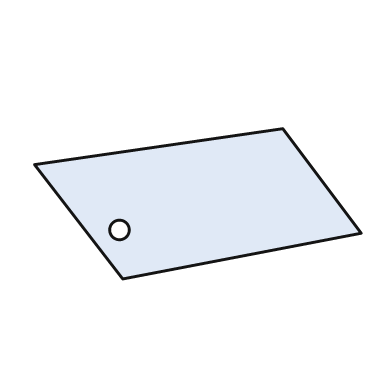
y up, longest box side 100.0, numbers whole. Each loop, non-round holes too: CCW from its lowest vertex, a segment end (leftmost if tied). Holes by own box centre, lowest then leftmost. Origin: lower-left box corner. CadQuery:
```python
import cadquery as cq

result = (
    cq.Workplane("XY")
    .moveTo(27.0, 0.0)
    .lineTo(100.0, 14.0)
    .lineTo(76.0, 46.0)
    .lineTo(0.0, 35.0)
    .close()
    .moveTo(26.0, 15.0)
    .circle(3.0)
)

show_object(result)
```